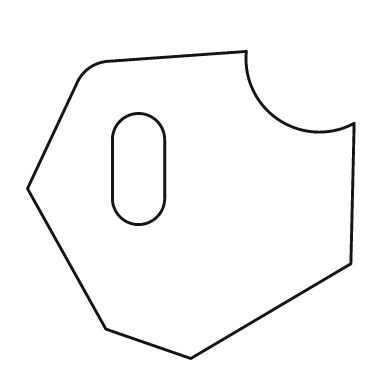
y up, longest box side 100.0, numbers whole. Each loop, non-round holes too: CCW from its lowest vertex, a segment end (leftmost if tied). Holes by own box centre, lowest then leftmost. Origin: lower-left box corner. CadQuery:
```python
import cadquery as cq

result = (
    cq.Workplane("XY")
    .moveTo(50.0, 0.0)
    .lineTo(99.0, 29.0)
    .lineTo(100.0, 72.0)
    .threePointArc((77.0, 73.0), (67.0, 94.0))
    .lineTo(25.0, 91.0)
    .threePointArc((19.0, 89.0), (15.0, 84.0))
    .lineTo(0.0, 52.0)
    .lineTo(24.0, 9.0)
    .close()
    .moveTo(26.0, 49.0)
    .threePointArc((34.0, 41.0), (42.0, 49.0))
    .lineTo(42.0, 67.0)
    .threePointArc((34.0, 75.0), (26.0, 67.0))
    .close()
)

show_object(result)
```